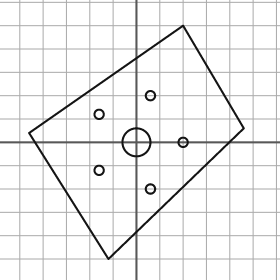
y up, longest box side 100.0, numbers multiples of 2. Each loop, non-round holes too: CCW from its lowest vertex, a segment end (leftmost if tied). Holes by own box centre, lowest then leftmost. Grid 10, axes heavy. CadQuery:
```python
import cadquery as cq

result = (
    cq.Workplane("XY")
    .moveTo(-12.0, -50.0)
    .lineTo(46.0, 6.0)
    .lineTo(20.0, 50.0)
    .lineTo(-46.0, 4.0)
    .close()
    .moveTo(6.0, -20.0)
    .circle(2.0)
    .moveTo(-16.0, -12.0)
    .circle(2.0)
    .moveTo(0.0, 0.0)
    .circle(6.0)
    .moveTo(20.0, 0.0)
    .circle(2.0)
    .moveTo(-16.0, 12.0)
    .circle(2.0)
    .moveTo(6.0, 20.0)
    .circle(2.0)
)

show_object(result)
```